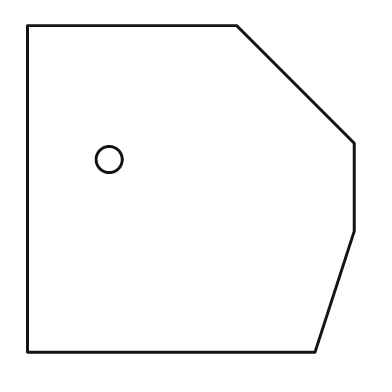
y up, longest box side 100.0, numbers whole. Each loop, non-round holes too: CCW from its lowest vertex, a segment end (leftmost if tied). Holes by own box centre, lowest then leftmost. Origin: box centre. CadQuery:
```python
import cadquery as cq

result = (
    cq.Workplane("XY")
    .moveTo(-50.0, -50.0)
    .lineTo(38.0, -50.0)
    .lineTo(50.0, -13.0)
    .lineTo(50.0, 14.0)
    .lineTo(14.0, 50.0)
    .lineTo(-50.0, 50.0)
    .close()
    .moveTo(-25.0, 9.0)
    .circle(4.0)
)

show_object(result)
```